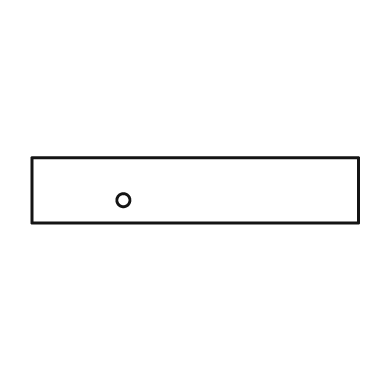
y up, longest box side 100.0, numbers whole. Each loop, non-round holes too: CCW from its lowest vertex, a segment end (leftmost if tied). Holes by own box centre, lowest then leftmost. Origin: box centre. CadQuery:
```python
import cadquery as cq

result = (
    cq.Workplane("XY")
    .moveTo(-50.0, -10.0)
    .lineTo(50.0, -10.0)
    .lineTo(50.0, 10.0)
    .lineTo(-50.0, 10.0)
    .close()
    .moveTo(-22.0, -3.0)
    .circle(2.0)
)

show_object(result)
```